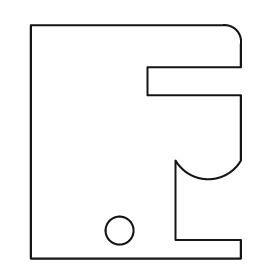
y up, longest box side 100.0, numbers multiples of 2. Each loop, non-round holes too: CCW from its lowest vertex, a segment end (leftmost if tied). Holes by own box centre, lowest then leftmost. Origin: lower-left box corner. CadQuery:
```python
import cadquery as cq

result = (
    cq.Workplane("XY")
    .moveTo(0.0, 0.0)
    .lineTo(90.0, 0.0)
    .lineTo(90.0, 8.0)
    .lineTo(62.0, 8.0)
    .lineTo(62.0, 42.0)
    .threePointArc((76.0, 34.0), (90.0, 42.0))
    .lineTo(90.0, 70.0)
    .lineTo(50.0, 70.0)
    .lineTo(50.0, 82.0)
    .lineTo(90.0, 82.0)
    .lineTo(90.0, 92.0)
    .threePointArc((88.0, 98.0), (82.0, 100.0))
    .lineTo(0.0, 100.0)
    .close()
    .moveTo(38.0, 12.0)
    .circle(6.0)
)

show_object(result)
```